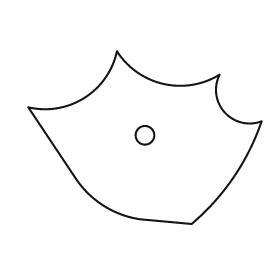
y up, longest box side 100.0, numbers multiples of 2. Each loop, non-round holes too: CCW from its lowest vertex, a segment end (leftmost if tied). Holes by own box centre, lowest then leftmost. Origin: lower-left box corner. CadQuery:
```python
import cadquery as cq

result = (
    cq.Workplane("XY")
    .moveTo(70.0, 0.0)
    .threePointArc((88.0, 20.0), (100.0, 44.0))
    .threePointArc((84.0, 48.0), (82.0, 64.0))
    .threePointArc((58.0, 60.0), (38.0, 74.0))
    .threePointArc((24.0, 54.0), (0.0, 50.0))
    .lineTo(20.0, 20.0)
    .threePointArc((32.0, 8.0), (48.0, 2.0))
    .close()
    .moveTo(50.0, 38.0)
    .circle(4.0)
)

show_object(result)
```